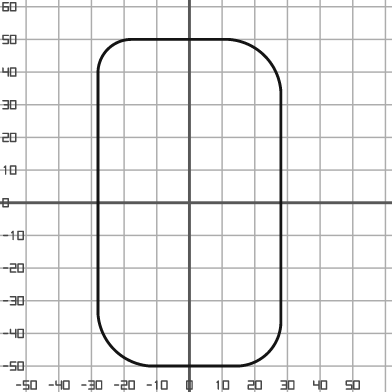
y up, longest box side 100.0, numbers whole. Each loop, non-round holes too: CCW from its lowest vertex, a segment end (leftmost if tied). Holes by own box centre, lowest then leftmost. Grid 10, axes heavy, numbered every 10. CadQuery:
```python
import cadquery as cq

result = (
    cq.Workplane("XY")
    .moveTo(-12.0, -50.0)
    .lineTo(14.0, -50.0)
    .threePointArc((24.0, -46.0), (28.0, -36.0))
    .lineTo(28.0, 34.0)
    .threePointArc((23.0, 45.0), (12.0, 50.0))
    .lineTo(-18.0, 50.0)
    .threePointArc((-25.0, 47.0), (-28.0, 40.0))
    .lineTo(-28.0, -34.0)
    .threePointArc((-23.0, -45.0), (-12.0, -50.0))
    .close()
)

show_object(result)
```